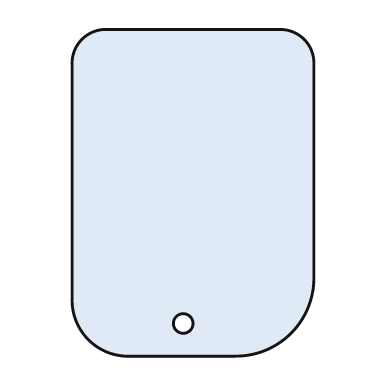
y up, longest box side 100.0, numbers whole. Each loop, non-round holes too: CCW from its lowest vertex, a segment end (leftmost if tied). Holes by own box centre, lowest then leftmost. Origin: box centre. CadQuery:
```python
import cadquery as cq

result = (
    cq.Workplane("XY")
    .moveTo(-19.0, -50.0)
    .lineTo(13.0, -50.0)
    .threePointArc((30.0, -43.0), (37.0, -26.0))
    .lineTo(37.0, 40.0)
    .threePointArc((34.0, 47.0), (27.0, 50.0))
    .lineTo(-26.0, 50.0)
    .threePointArc((-34.0, 47.0), (-37.0, 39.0))
    .lineTo(-37.0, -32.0)
    .threePointArc((-32.0, -45.0), (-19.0, -50.0))
    .close()
    .moveTo(-3.0, -40.0)
    .circle(3.0)
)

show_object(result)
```